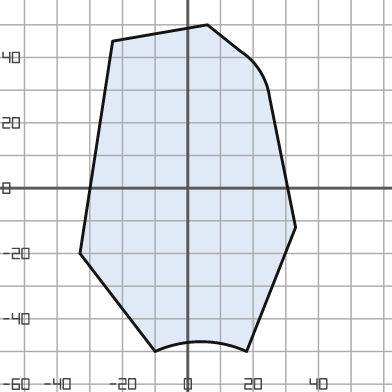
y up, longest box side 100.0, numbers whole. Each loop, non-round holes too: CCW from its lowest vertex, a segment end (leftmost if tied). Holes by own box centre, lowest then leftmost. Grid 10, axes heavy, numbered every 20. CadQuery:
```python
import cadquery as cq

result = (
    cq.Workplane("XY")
    .moveTo(-10.0, -50.0)
    .threePointArc((4.0, -47.0), (18.0, -50.0))
    .lineTo(33.0, -12.0)
    .lineTo(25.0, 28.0)
    .threePointArc((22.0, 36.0), (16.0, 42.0))
    .lineTo(6.0, 50.0)
    .lineTo(-23.0, 45.0)
    .lineTo(-33.0, -20.0)
    .close()
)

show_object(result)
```